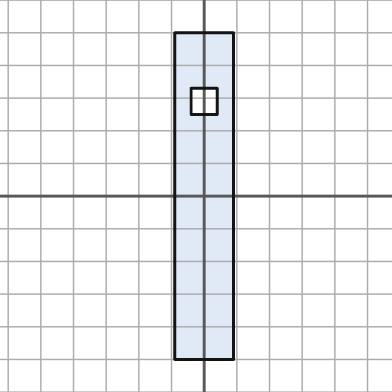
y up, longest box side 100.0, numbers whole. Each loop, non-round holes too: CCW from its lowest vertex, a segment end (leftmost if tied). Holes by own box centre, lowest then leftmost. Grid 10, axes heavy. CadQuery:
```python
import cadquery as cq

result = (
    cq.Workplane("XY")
    .moveTo(-9.0, -50.0)
    .lineTo(9.0, -50.0)
    .lineTo(9.0, 50.0)
    .lineTo(-9.0, 50.0)
    .close()
    .moveTo(-4.0, 25.0)
    .lineTo(4.0, 25.0)
    .lineTo(4.0, 33.0)
    .lineTo(-4.0, 33.0)
    .close()
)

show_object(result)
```